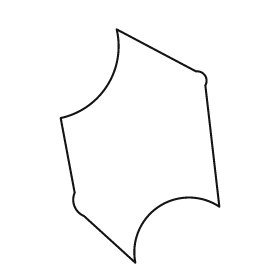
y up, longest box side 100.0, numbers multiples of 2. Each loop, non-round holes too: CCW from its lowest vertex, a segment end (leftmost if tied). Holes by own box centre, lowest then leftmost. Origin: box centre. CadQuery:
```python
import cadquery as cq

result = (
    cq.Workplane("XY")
    .moveTo(-2.0, -50.0)
    .threePointArc((8.0, -26.0), (34.0, -26.0))
    .lineTo(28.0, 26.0)
    .threePointArc((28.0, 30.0), (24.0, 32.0))
    .lineTo(-10.0, 50.0)
    .threePointArc((-14.0, 26.0), (-34.0, 12.0))
    .lineTo(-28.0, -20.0)
    .threePointArc((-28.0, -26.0), (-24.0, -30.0))
    .close()
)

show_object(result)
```